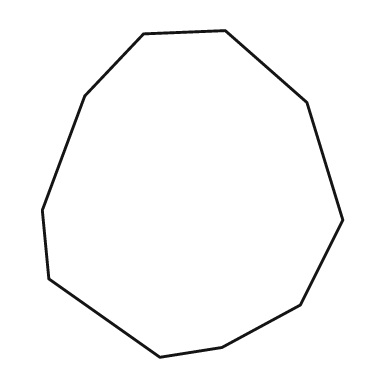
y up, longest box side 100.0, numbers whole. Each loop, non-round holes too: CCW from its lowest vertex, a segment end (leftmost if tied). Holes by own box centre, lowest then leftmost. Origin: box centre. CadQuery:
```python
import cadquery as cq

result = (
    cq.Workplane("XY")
    .moveTo(-10.0, -50.0)
    .lineTo(9.0, -47.0)
    .lineTo(33.0, -34.0)
    .lineTo(46.0, -8.0)
    .lineTo(35.0, 28.0)
    .lineTo(10.0, 50.0)
    .lineTo(-15.0, 49.0)
    .lineTo(-33.0, 30.0)
    .lineTo(-46.0, -5.0)
    .lineTo(-44.0, -26.0)
    .close()
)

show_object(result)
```